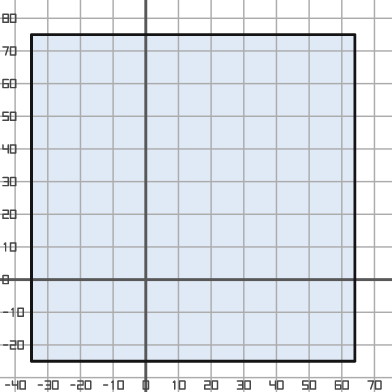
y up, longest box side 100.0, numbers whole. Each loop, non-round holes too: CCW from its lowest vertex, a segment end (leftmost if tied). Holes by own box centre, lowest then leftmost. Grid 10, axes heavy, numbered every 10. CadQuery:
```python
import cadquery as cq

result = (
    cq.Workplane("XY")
    .moveTo(-35.0, -25.0)
    .lineTo(64.0, -25.0)
    .lineTo(64.0, 75.0)
    .lineTo(-35.0, 75.0)
    .close()
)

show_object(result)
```